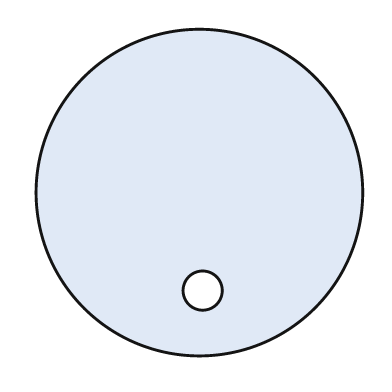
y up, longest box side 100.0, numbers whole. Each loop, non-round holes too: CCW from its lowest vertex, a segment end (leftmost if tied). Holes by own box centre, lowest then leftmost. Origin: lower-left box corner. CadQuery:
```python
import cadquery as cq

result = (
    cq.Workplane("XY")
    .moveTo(50.0, 50.0)
    .circle(50.0)
    .moveTo(51.0, 20.0)
    .circle(6.0)
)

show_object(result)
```